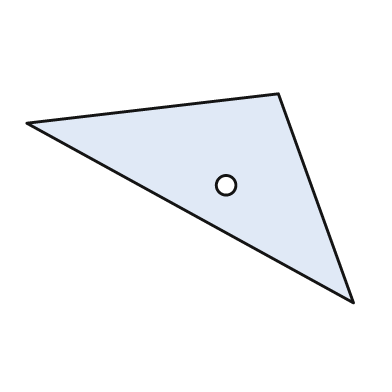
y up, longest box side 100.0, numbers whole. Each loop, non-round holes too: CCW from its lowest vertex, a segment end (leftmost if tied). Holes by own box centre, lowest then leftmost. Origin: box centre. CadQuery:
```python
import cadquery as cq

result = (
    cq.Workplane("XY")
    .moveTo(50.0, -32.0)
    .lineTo(27.0, 32.0)
    .lineTo(-50.0, 23.0)
    .close()
    .moveTo(11.0, 4.0)
    .circle(3.0)
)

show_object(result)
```